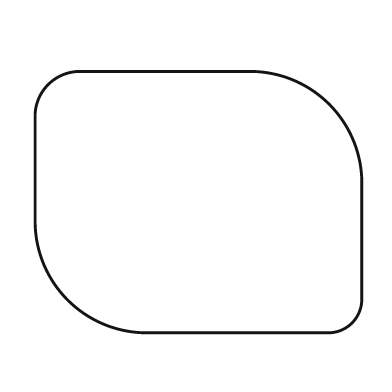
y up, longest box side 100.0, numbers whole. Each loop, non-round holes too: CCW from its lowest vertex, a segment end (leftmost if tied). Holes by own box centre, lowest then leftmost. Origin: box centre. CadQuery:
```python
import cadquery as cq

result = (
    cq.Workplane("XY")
    .moveTo(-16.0, -40.0)
    .lineTo(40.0, -40.0)
    .threePointArc((47.0, -37.0), (50.0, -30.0))
    .lineTo(50.0, 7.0)
    .threePointArc((40.0, 30.0), (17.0, 40.0))
    .lineTo(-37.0, 40.0)
    .threePointArc((-46.0, 36.0), (-50.0, 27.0))
    .lineTo(-50.0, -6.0)
    .threePointArc((-40.0, -30.0), (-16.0, -40.0))
    .close()
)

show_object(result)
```